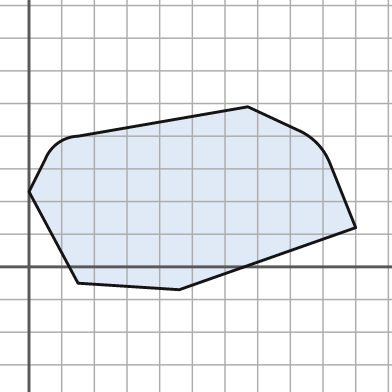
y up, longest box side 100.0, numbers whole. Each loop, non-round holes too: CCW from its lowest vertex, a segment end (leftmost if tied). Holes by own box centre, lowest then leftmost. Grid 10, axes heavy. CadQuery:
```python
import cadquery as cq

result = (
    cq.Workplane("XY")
    .moveTo(46.0, -7.0)
    .lineTo(100.0, 12.0)
    .lineTo(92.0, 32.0)
    .threePointArc((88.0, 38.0), (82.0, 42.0))
    .lineTo(67.0, 49.0)
    .lineTo(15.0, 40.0)
    .threePointArc((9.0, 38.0), (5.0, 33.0))
    .lineTo(0.0, 23.0)
    .lineTo(15.0, -5.0)
    .close()
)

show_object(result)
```